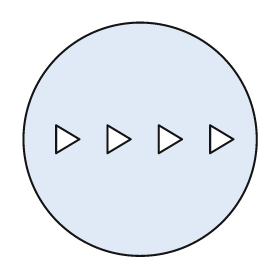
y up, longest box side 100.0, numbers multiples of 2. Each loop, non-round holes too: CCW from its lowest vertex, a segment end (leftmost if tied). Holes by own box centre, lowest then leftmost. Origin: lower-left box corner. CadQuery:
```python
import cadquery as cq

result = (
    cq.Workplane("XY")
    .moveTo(50.0, 50.0)
    .circle(50.0)
    .moveTo(14.0, 44.0)
    .lineTo(24.0, 50.0)
    .lineTo(14.0, 56.0)
    .close()
    .moveTo(36.0, 44.0)
    .lineTo(46.0, 50.0)
    .lineTo(36.0, 56.0)
    .close()
    .moveTo(58.0, 44.0)
    .lineTo(68.0, 50.0)
    .lineTo(58.0, 56.0)
    .close()
    .moveTo(80.0, 44.0)
    .lineTo(90.0, 50.0)
    .lineTo(80.0, 56.0)
    .close()
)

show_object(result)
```